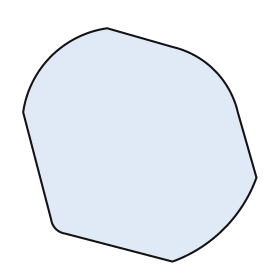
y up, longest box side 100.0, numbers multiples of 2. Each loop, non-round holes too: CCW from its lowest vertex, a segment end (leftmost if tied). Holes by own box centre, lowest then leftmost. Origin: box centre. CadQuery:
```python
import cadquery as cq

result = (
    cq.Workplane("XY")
    .moveTo(14.0, -50.0)
    .threePointArc((36.0, -36.0), (50.0, -14.0))
    .lineTo(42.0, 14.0)
    .threePointArc((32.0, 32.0), (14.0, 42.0))
    .lineTo(-14.0, 50.0)
    .threePointArc((-38.0, 38.0), (-50.0, 14.0))
    .lineTo(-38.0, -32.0)
    .threePointArc((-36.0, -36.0), (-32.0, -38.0))
    .close()
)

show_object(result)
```